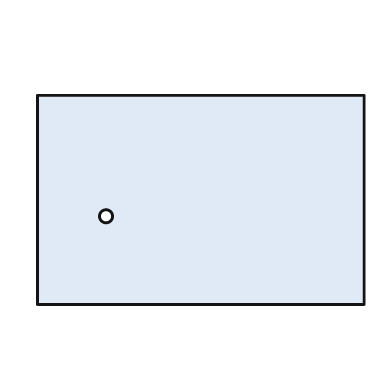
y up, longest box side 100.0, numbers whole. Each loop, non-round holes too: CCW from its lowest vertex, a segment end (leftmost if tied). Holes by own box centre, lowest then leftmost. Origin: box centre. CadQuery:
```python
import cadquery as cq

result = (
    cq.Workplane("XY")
    .moveTo(-50.0, -32.0)
    .lineTo(50.0, -32.0)
    .lineTo(50.0, 32.0)
    .lineTo(-50.0, 32.0)
    .close()
    .moveTo(-29.0, -5.0)
    .circle(2.0)
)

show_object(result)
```